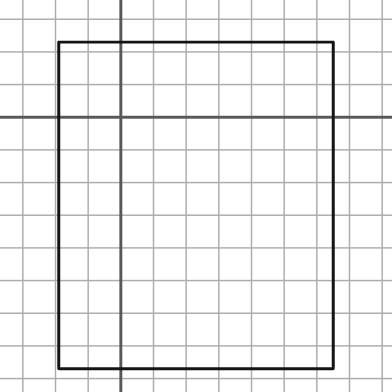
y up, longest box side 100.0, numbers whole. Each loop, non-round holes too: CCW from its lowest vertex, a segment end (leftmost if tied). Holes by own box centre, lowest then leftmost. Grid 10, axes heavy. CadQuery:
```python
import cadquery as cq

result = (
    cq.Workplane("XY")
    .moveTo(-19.0, -77.0)
    .lineTo(65.0, -77.0)
    .lineTo(65.0, 23.0)
    .lineTo(-19.0, 23.0)
    .close()
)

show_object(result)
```